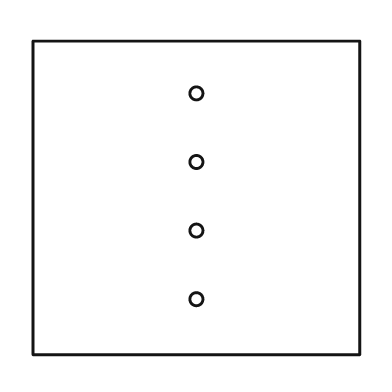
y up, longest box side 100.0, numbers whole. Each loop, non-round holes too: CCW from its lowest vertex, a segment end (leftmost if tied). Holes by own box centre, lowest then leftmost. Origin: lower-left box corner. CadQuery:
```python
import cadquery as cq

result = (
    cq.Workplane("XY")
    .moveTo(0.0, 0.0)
    .lineTo(100.0, 0.0)
    .lineTo(100.0, 96.0)
    .lineTo(0.0, 96.0)
    .close()
    .moveTo(50.0, 17.0)
    .circle(2.0)
    .moveTo(50.0, 38.0)
    .circle(2.0)
    .moveTo(50.0, 59.0)
    .circle(2.0)
    .moveTo(50.0, 80.0)
    .circle(2.0)
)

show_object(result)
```